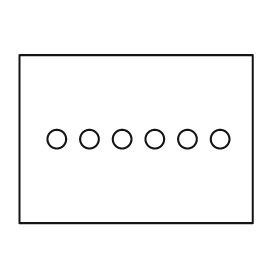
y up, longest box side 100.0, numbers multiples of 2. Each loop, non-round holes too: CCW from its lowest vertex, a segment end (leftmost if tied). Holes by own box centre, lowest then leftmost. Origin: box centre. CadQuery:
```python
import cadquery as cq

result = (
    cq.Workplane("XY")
    .moveTo(-50.0, -36.0)
    .lineTo(50.0, -36.0)
    .lineTo(50.0, 36.0)
    .lineTo(-50.0, 36.0)
    .close()
    .moveTo(-34.0, 0.0)
    .circle(4.0)
    .moveTo(-20.0, 0.0)
    .circle(4.0)
    .moveTo(-6.0, 0.0)
    .circle(4.0)
    .moveTo(8.0, 0.0)
    .circle(4.0)
    .moveTo(22.0, 0.0)
    .circle(4.0)
    .moveTo(36.0, 0.0)
    .circle(4.0)
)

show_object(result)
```